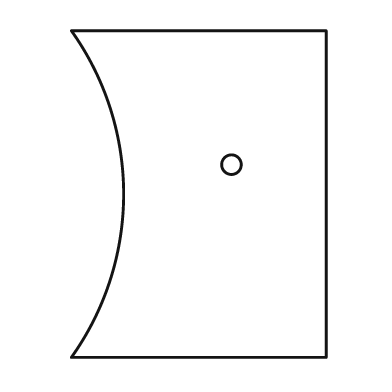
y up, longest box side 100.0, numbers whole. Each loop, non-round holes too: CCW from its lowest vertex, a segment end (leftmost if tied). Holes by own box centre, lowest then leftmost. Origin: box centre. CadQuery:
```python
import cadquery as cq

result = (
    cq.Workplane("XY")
    .moveTo(-39.0, -50.0)
    .lineTo(39.0, -50.0)
    .lineTo(39.0, 50.0)
    .lineTo(-39.0, 50.0)
    .threePointArc((-23.0, 0.0), (-39.0, -50.0))
    .close()
    .moveTo(10.0, 9.0)
    .circle(3.0)
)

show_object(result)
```